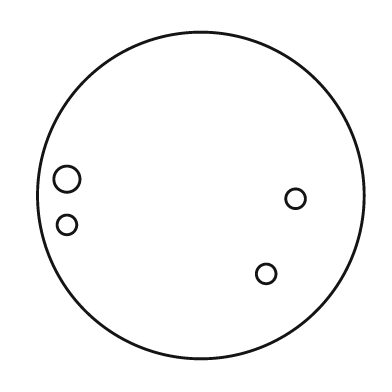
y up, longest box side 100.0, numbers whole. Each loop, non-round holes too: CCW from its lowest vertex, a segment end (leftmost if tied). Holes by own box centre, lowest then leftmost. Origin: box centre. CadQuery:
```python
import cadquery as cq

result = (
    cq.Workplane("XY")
    .moveTo(0.0, 0.0)
    .circle(50.0)
    .moveTo(20.0, -24.0)
    .circle(3.0)
    .moveTo(-41.0, -9.0)
    .circle(3.0)
    .moveTo(29.0, -1.0)
    .circle(3.0)
    .moveTo(-41.0, 5.0)
    .circle(4.0)
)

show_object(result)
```